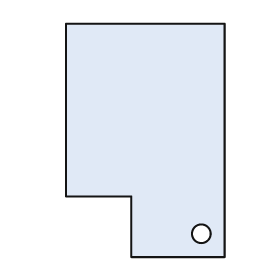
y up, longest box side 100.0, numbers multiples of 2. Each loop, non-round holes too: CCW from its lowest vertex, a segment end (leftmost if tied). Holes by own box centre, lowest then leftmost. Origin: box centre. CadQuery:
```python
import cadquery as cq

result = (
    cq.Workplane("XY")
    .moveTo(-6.0, -50.0)
    .lineTo(34.0, -50.0)
    .lineTo(34.0, 50.0)
    .lineTo(-34.0, 50.0)
    .lineTo(-34.0, -24.0)
    .lineTo(-6.0, -24.0)
    .close()
    .moveTo(24.0, -40.0)
    .circle(4.0)
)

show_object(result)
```